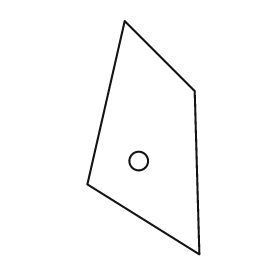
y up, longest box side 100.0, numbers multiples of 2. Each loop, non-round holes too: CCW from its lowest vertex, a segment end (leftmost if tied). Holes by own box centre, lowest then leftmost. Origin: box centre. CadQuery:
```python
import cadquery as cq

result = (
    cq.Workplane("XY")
    .moveTo(24.0, -50.0)
    .lineTo(22.0, 20.0)
    .lineTo(-8.0, 50.0)
    .lineTo(-24.0, -20.0)
    .close()
    .moveTo(-2.0, -10.0)
    .circle(4.0)
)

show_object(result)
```